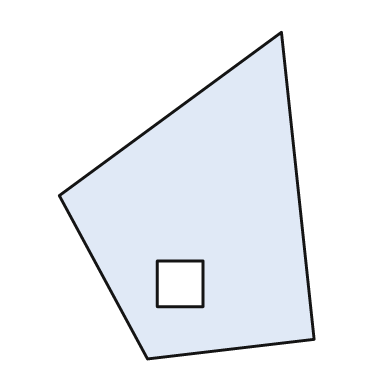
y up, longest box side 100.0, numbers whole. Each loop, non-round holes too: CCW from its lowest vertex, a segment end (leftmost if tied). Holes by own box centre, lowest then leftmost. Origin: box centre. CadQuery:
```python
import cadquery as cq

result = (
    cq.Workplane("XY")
    .moveTo(-12.0, -50.0)
    .lineTo(39.0, -44.0)
    .lineTo(29.0, 50.0)
    .lineTo(-39.0, 0.0)
    .close()
    .moveTo(-9.0, -34.0)
    .lineTo(5.0, -34.0)
    .lineTo(5.0, -20.0)
    .lineTo(-9.0, -20.0)
    .close()
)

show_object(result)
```